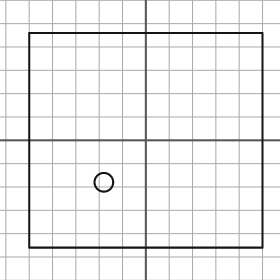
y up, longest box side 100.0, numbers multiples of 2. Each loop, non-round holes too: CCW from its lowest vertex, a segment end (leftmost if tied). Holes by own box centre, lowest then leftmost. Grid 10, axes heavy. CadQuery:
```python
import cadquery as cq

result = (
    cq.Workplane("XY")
    .moveTo(-50.0, -46.0)
    .lineTo(50.0, -46.0)
    .lineTo(50.0, 46.0)
    .lineTo(-50.0, 46.0)
    .close()
    .moveTo(-18.0, -18.0)
    .circle(4.0)
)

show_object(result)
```